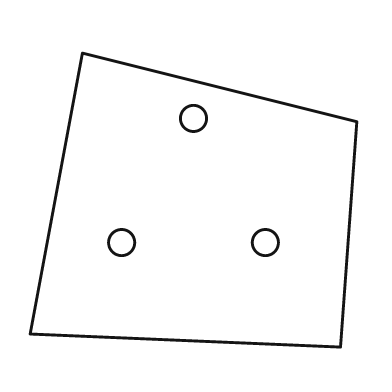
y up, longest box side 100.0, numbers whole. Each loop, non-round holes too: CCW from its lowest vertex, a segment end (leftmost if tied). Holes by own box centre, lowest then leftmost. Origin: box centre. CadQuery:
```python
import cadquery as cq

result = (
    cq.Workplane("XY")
    .moveTo(45.0, -45.0)
    .lineTo(50.0, 24.0)
    .lineTo(-34.0, 45.0)
    .lineTo(-50.0, -41.0)
    .close()
    .moveTo(-22.0, -13.0)
    .circle(4.0)
    .moveTo(22.0, -13.0)
    .circle(4.0)
    .moveTo(0.0, 25.0)
    .circle(4.0)
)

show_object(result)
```